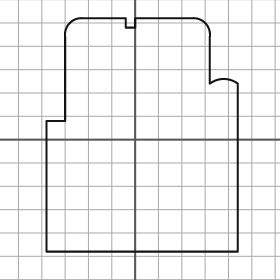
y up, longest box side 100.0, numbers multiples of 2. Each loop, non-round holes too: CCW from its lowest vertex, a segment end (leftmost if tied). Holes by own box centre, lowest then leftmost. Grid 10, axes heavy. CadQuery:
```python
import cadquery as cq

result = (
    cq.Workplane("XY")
    .moveTo(-38.0, -48.0)
    .lineTo(44.0, -48.0)
    .lineTo(44.0, 24.0)
    .threePointArc((38.0, 26.0), (32.0, 24.0))
    .lineTo(32.0, 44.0)
    .threePointArc((30.0, 50.0), (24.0, 52.0))
    .lineTo(0.0, 52.0)
    .lineTo(0.0, 48.0)
    .lineTo(-4.0, 48.0)
    .lineTo(-4.0, 52.0)
    .lineTo(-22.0, 52.0)
    .threePointArc((-28.0, 50.0), (-30.0, 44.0))
    .lineTo(-30.0, 8.0)
    .lineTo(-38.0, 8.0)
    .close()
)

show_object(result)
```